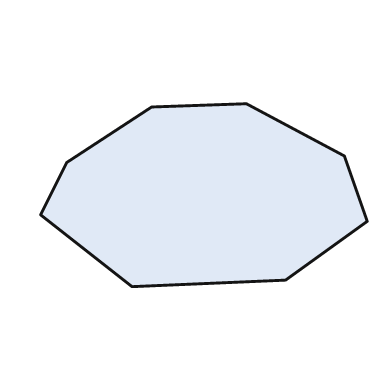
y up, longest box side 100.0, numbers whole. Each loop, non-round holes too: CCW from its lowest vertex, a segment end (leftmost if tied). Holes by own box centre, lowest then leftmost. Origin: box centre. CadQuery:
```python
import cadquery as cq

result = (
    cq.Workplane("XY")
    .moveTo(-22.0, -28.0)
    .lineTo(25.0, -26.0)
    .lineTo(50.0, -8.0)
    .lineTo(43.0, 12.0)
    .lineTo(13.0, 28.0)
    .lineTo(-16.0, 27.0)
    .lineTo(-42.0, 10.0)
    .lineTo(-50.0, -6.0)
    .close()
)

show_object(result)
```